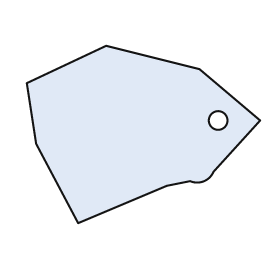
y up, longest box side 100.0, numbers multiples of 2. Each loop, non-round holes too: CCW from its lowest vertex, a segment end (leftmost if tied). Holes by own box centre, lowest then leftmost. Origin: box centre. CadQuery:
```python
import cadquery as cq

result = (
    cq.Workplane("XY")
    .moveTo(-28.0, -38.0)
    .lineTo(10.0, -22.0)
    .lineTo(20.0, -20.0)
    .threePointArc((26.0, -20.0), (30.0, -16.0))
    .lineTo(50.0, 6.0)
    .lineTo(24.0, 28.0)
    .lineTo(-16.0, 38.0)
    .lineTo(-50.0, 22.0)
    .lineTo(-46.0, -4.0)
    .close()
    .moveTo(32.0, 6.0)
    .circle(4.0)
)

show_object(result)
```